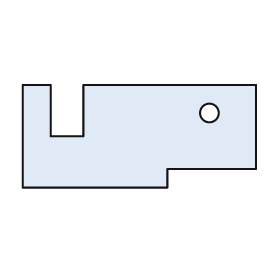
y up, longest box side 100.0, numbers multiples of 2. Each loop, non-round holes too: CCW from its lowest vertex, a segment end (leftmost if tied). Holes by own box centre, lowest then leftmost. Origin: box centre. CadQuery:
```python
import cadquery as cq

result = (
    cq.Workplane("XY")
    .moveTo(-50.0, -22.0)
    .lineTo(12.0, -22.0)
    .lineTo(12.0, -14.0)
    .lineTo(50.0, -14.0)
    .lineTo(50.0, 22.0)
    .lineTo(-24.0, 22.0)
    .lineTo(-24.0, 0.0)
    .lineTo(-38.0, 0.0)
    .lineTo(-38.0, 22.0)
    .lineTo(-50.0, 22.0)
    .close()
    .moveTo(30.0, 10.0)
    .circle(4.0)
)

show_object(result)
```